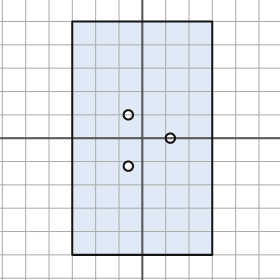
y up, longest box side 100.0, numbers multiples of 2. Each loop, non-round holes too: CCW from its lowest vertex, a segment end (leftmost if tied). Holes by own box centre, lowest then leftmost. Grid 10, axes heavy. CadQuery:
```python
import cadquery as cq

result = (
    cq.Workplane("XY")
    .moveTo(-30.0, -50.0)
    .lineTo(30.0, -50.0)
    .lineTo(30.0, 50.0)
    .lineTo(-30.0, 50.0)
    .close()
    .moveTo(-6.0, -12.0)
    .circle(2.0)
    .moveTo(12.0, 0.0)
    .circle(2.0)
    .moveTo(-6.0, 10.0)
    .circle(2.0)
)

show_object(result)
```